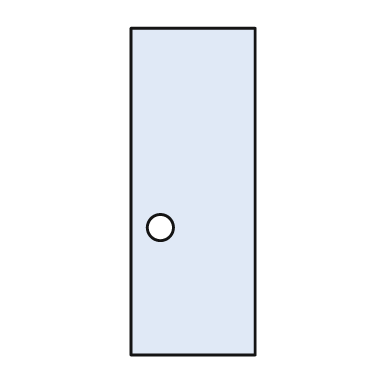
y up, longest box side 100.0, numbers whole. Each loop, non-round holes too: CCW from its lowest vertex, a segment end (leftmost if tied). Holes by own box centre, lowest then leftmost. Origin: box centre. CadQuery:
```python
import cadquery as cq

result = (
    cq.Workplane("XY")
    .moveTo(-19.0, -50.0)
    .lineTo(19.0, -50.0)
    .lineTo(19.0, 50.0)
    .lineTo(-19.0, 50.0)
    .close()
    .moveTo(-10.0, -11.0)
    .circle(4.0)
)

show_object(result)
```